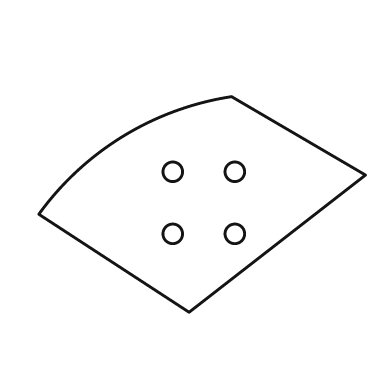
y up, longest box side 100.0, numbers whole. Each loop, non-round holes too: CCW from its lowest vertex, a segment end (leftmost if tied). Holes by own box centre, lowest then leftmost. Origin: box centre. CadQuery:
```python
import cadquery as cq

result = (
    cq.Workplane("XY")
    .moveTo(-4.0, -33.0)
    .lineTo(50.0, 9.0)
    .lineTo(9.0, 33.0)
    .threePointArc((-24.0, 21.0), (-50.0, -3.0))
    .close()
    .moveTo(-9.0, -9.0)
    .circle(3.0)
    .moveTo(10.0, -9.0)
    .circle(3.0)
    .moveTo(-9.0, 10.0)
    .circle(3.0)
    .moveTo(10.0, 10.0)
    .circle(3.0)
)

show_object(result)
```